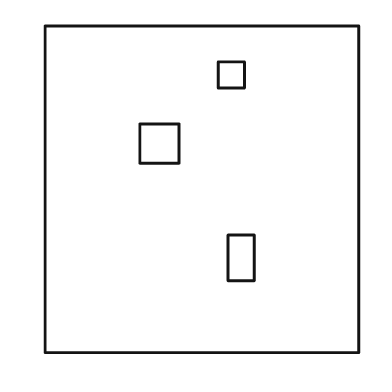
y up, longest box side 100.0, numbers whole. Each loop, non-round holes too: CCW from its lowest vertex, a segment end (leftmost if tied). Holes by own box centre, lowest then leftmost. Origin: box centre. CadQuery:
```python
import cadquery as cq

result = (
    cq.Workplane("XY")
    .moveTo(-48.0, -50.0)
    .lineTo(48.0, -50.0)
    .lineTo(48.0, 50.0)
    .lineTo(-48.0, 50.0)
    .close()
    .moveTo(8.0, -28.0)
    .lineTo(16.0, -28.0)
    .lineTo(16.0, -14.0)
    .lineTo(8.0, -14.0)
    .close()
    .moveTo(-19.0, 8.0)
    .lineTo(-7.0, 8.0)
    .lineTo(-7.0, 20.0)
    .lineTo(-19.0, 20.0)
    .close()
    .moveTo(5.0, 31.0)
    .lineTo(13.0, 31.0)
    .lineTo(13.0, 39.0)
    .lineTo(5.0, 39.0)
    .close()
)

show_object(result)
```